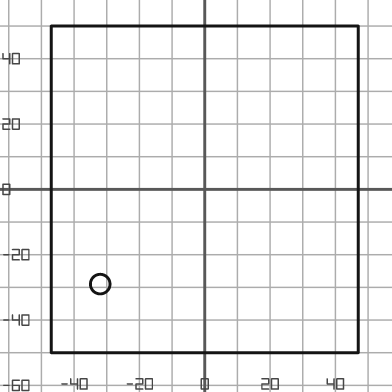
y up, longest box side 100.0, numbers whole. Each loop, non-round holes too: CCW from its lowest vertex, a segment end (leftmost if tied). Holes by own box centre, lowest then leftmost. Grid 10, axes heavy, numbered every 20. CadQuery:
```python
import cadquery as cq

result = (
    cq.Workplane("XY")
    .moveTo(-47.0, -50.0)
    .lineTo(47.0, -50.0)
    .lineTo(47.0, 50.0)
    .lineTo(-47.0, 50.0)
    .close()
    .moveTo(-32.0, -29.0)
    .circle(3.0)
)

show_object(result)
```